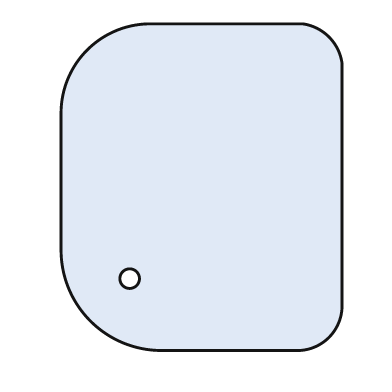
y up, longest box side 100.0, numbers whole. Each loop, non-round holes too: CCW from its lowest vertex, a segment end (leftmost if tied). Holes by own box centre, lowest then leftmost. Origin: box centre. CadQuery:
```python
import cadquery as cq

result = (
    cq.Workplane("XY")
    .moveTo(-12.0, -50.0)
    .lineTo(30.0, -50.0)
    .threePointArc((39.0, -46.0), (43.0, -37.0))
    .lineTo(43.0, 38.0)
    .threePointArc((39.0, 46.0), (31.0, 50.0))
    .lineTo(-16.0, 50.0)
    .threePointArc((-35.0, 42.0), (-43.0, 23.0))
    .lineTo(-43.0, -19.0)
    .threePointArc((-34.0, -41.0), (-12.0, -50.0))
    .close()
    .moveTo(-22.0, -28.0)
    .circle(3.0)
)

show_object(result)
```